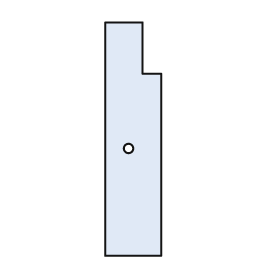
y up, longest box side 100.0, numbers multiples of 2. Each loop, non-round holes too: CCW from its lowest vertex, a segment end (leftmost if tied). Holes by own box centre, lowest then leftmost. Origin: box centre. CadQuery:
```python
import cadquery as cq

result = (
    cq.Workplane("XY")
    .moveTo(-12.0, -50.0)
    .lineTo(12.0, -50.0)
    .lineTo(12.0, 28.0)
    .lineTo(4.0, 28.0)
    .lineTo(4.0, 50.0)
    .lineTo(-12.0, 50.0)
    .close()
    .moveTo(-2.0, -4.0)
    .circle(2.0)
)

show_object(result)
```